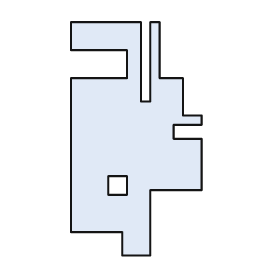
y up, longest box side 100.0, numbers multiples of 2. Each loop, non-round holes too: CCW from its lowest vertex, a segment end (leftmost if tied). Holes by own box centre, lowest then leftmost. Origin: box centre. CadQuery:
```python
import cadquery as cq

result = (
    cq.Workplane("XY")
    .moveTo(-6.0, -50.0)
    .lineTo(6.0, -50.0)
    .lineTo(6.0, -22.0)
    .lineTo(28.0, -22.0)
    .lineTo(28.0, 0.0)
    .lineTo(16.0, 0.0)
    .lineTo(16.0, 6.0)
    .lineTo(28.0, 6.0)
    .lineTo(28.0, 10.0)
    .lineTo(20.0, 10.0)
    .lineTo(20.0, 26.0)
    .lineTo(10.0, 26.0)
    .lineTo(10.0, 50.0)
    .lineTo(6.0, 50.0)
    .lineTo(6.0, 16.0)
    .lineTo(2.0, 16.0)
    .lineTo(2.0, 50.0)
    .lineTo(-28.0, 50.0)
    .lineTo(-28.0, 38.0)
    .lineTo(-4.0, 38.0)
    .lineTo(-4.0, 26.0)
    .lineTo(-28.0, 26.0)
    .lineTo(-28.0, -40.0)
    .lineTo(-6.0, -40.0)
    .close()
    .moveTo(-12.0, -24.0)
    .lineTo(-4.0, -24.0)
    .lineTo(-4.0, -16.0)
    .lineTo(-12.0, -16.0)
    .close()
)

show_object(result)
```